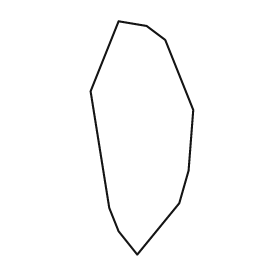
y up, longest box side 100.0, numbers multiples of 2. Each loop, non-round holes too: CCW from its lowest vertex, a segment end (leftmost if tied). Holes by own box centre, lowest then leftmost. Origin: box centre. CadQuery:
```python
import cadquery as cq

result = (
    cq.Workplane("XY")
    .moveTo(-2.0, -50.0)
    .lineTo(16.0, -28.0)
    .lineTo(20.0, -14.0)
    .lineTo(22.0, 12.0)
    .lineTo(10.0, 42.0)
    .lineTo(2.0, 48.0)
    .lineTo(-10.0, 50.0)
    .lineTo(-22.0, 20.0)
    .lineTo(-14.0, -30.0)
    .lineTo(-10.0, -40.0)
    .close()
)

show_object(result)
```